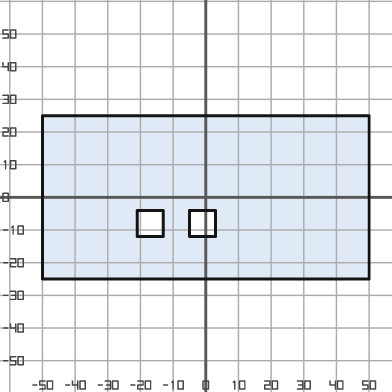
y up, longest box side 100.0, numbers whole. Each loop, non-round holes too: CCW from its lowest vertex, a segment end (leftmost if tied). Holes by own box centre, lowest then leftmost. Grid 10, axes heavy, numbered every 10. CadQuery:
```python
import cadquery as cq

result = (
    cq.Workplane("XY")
    .moveTo(-50.0, -25.0)
    .lineTo(50.0, -25.0)
    .lineTo(50.0, 25.0)
    .lineTo(-50.0, 25.0)
    .close()
    .moveTo(-21.0, -12.0)
    .lineTo(-13.0, -12.0)
    .lineTo(-13.0, -4.0)
    .lineTo(-21.0, -4.0)
    .close()
    .moveTo(-5.0, -12.0)
    .lineTo(3.0, -12.0)
    .lineTo(3.0, -4.0)
    .lineTo(-5.0, -4.0)
    .close()
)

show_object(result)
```